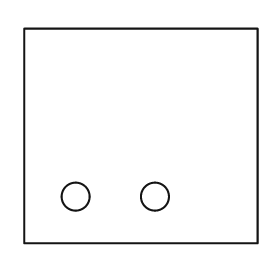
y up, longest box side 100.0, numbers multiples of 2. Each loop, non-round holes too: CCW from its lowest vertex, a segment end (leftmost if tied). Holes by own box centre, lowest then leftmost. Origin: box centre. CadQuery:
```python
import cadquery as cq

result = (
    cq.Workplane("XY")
    .moveTo(-50.0, -46.0)
    .lineTo(50.0, -46.0)
    .lineTo(50.0, 46.0)
    .lineTo(-50.0, 46.0)
    .close()
    .moveTo(-28.0, -26.0)
    .circle(6.0)
    .moveTo(6.0, -26.0)
    .circle(6.0)
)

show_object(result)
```